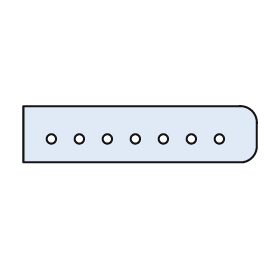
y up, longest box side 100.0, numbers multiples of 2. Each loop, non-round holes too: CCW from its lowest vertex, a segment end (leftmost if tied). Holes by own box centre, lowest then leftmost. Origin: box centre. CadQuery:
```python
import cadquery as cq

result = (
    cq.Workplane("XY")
    .moveTo(-50.0, -12.0)
    .lineTo(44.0, -12.0)
    .threePointArc((48.0, -10.0), (50.0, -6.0))
    .lineTo(50.0, 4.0)
    .threePointArc((48.0, 10.0), (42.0, 12.0))
    .lineTo(-50.0, 12.0)
    .close()
    .moveTo(-38.0, -2.0)
    .circle(2.0)
    .moveTo(-26.0, -2.0)
    .circle(2.0)
    .moveTo(-14.0, -2.0)
    .circle(2.0)
    .moveTo(-2.0, -2.0)
    .circle(2.0)
    .moveTo(10.0, -2.0)
    .circle(2.0)
    .moveTo(22.0, -2.0)
    .circle(2.0)
    .moveTo(34.0, -2.0)
    .circle(2.0)
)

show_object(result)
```